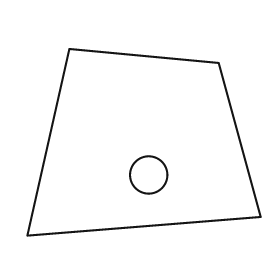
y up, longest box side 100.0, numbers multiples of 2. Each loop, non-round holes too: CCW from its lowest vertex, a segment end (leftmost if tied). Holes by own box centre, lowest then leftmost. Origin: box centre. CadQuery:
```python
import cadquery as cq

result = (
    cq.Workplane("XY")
    .moveTo(-50.0, -40.0)
    .lineTo(50.0, -32.0)
    .lineTo(32.0, 34.0)
    .lineTo(-32.0, 40.0)
    .close()
    .moveTo(2.0, -14.0)
    .circle(8.0)
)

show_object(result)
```